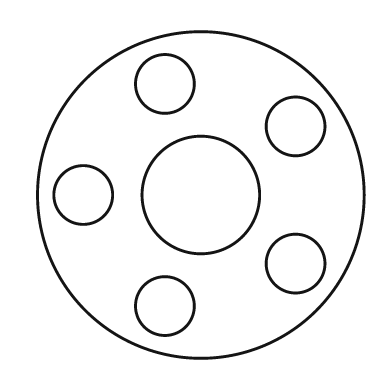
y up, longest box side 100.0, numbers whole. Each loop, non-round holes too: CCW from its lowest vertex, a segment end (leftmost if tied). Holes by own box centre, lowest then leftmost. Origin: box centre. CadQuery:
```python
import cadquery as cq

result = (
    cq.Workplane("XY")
    .moveTo(0.0, 0.0)
    .circle(50.0)
    .moveTo(-11.0, -34.0)
    .circle(9.0)
    .moveTo(29.0, -21.0)
    .circle(9.0)
    .moveTo(-36.0, 0.0)
    .circle(9.0)
    .moveTo(0.0, 0.0)
    .circle(18.0)
    .moveTo(29.0, 21.0)
    .circle(9.0)
    .moveTo(-11.0, 34.0)
    .circle(9.0)
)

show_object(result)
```